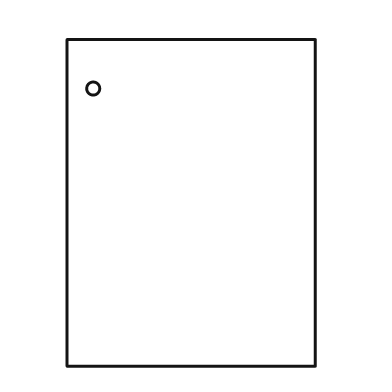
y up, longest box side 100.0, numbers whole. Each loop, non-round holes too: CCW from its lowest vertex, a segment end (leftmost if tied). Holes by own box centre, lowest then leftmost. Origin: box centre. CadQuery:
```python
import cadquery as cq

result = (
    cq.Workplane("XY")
    .moveTo(-38.0, -50.0)
    .lineTo(38.0, -50.0)
    .lineTo(38.0, 50.0)
    .lineTo(-38.0, 50.0)
    .close()
    .moveTo(-30.0, 35.0)
    .circle(2.0)
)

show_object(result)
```